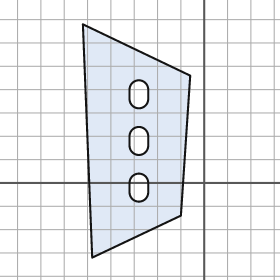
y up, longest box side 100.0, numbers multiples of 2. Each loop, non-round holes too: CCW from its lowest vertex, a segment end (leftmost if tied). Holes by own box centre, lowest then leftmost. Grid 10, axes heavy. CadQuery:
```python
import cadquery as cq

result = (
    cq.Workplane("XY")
    .moveTo(-48.0, -32.0)
    .lineTo(-10.0, -14.0)
    .lineTo(-6.0, 46.0)
    .lineTo(-52.0, 68.0)
    .close()
    .moveTo(-32.0, -4.0)
    .threePointArc((-28.0, -8.0), (-24.0, -4.0))
    .lineTo(-24.0, 0.0)
    .threePointArc((-28.0, 4.0), (-32.0, 0.0))
    .close()
    .moveTo(-32.0, 16.0)
    .threePointArc((-28.0, 12.0), (-24.0, 16.0))
    .lineTo(-24.0, 20.0)
    .threePointArc((-28.0, 24.0), (-32.0, 20.0))
    .close()
    .moveTo(-32.0, 36.0)
    .threePointArc((-28.0, 32.0), (-24.0, 36.0))
    .lineTo(-24.0, 40.0)
    .threePointArc((-28.0, 44.0), (-32.0, 40.0))
    .close()
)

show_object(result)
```